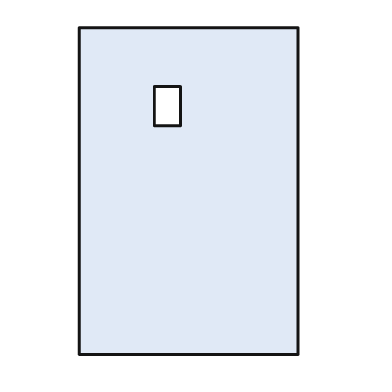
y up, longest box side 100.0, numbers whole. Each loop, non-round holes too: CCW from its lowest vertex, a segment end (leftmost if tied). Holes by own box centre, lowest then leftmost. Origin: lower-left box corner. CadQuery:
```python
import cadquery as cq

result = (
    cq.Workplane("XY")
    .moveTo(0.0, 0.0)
    .lineTo(67.0, 0.0)
    .lineTo(67.0, 100.0)
    .lineTo(0.0, 100.0)
    .close()
    .moveTo(23.0, 70.0)
    .lineTo(31.0, 70.0)
    .lineTo(31.0, 82.0)
    .lineTo(23.0, 82.0)
    .close()
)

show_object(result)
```